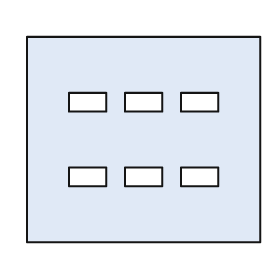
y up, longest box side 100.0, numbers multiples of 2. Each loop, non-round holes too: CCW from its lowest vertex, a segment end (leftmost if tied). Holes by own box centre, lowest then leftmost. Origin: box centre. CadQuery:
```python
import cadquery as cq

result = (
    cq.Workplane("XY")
    .moveTo(-50.0, -44.0)
    .lineTo(50.0, -44.0)
    .lineTo(50.0, 44.0)
    .lineTo(-50.0, 44.0)
    .close()
    .moveTo(-32.0, -20.0)
    .lineTo(-16.0, -20.0)
    .lineTo(-16.0, -12.0)
    .lineTo(-32.0, -12.0)
    .close()
    .moveTo(-8.0, -20.0)
    .lineTo(8.0, -20.0)
    .lineTo(8.0, -12.0)
    .lineTo(-8.0, -12.0)
    .close()
    .moveTo(16.0, -20.0)
    .lineTo(32.0, -20.0)
    .lineTo(32.0, -12.0)
    .lineTo(16.0, -12.0)
    .close()
    .moveTo(-32.0, 12.0)
    .lineTo(-16.0, 12.0)
    .lineTo(-16.0, 20.0)
    .lineTo(-32.0, 20.0)
    .close()
    .moveTo(-8.0, 12.0)
    .lineTo(8.0, 12.0)
    .lineTo(8.0, 20.0)
    .lineTo(-8.0, 20.0)
    .close()
    .moveTo(16.0, 12.0)
    .lineTo(32.0, 12.0)
    .lineTo(32.0, 20.0)
    .lineTo(16.0, 20.0)
    .close()
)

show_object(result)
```